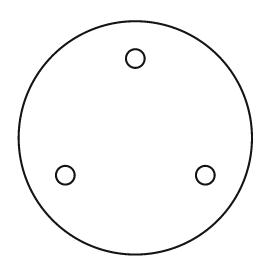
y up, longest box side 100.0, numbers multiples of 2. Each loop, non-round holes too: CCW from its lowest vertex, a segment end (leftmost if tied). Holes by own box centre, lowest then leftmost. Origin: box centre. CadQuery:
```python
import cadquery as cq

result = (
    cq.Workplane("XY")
    .moveTo(0.0, 0.0)
    .circle(50.0)
    .moveTo(-30.0, -16.0)
    .circle(4.0)
    .moveTo(30.0, -16.0)
    .circle(4.0)
    .moveTo(0.0, 34.0)
    .circle(4.0)
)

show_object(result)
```